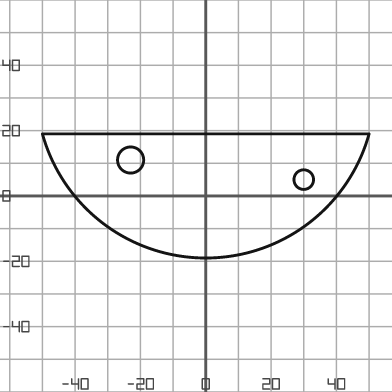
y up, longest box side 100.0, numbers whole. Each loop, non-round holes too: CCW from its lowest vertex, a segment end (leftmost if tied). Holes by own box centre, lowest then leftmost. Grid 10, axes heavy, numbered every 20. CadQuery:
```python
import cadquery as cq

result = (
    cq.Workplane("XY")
    .moveTo(-50.0, 19.0)
    .threePointArc((0.0, -19.0), (50.0, 19.0))
    .close()
    .moveTo(30.0, 5.0)
    .circle(3.0)
    .moveTo(-23.0, 11.0)
    .circle(4.0)
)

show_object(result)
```